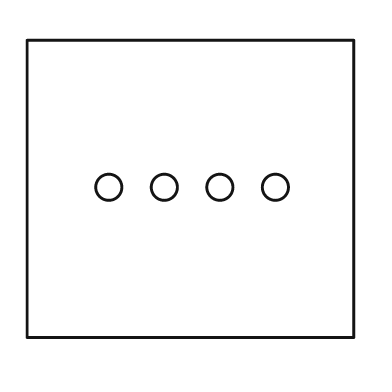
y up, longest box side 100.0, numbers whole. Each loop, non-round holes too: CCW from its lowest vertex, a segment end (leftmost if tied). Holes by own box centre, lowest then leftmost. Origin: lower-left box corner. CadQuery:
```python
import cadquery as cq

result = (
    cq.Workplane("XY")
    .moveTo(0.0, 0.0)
    .lineTo(100.0, 0.0)
    .lineTo(100.0, 91.0)
    .lineTo(0.0, 91.0)
    .close()
    .moveTo(25.0, 46.0)
    .circle(4.0)
    .moveTo(42.0, 46.0)
    .circle(4.0)
    .moveTo(59.0, 46.0)
    .circle(4.0)
    .moveTo(76.0, 46.0)
    .circle(4.0)
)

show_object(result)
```